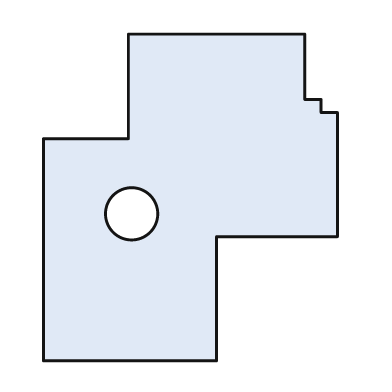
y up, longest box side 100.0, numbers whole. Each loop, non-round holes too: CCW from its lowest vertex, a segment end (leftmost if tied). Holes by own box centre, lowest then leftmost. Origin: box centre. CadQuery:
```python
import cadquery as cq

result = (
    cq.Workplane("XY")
    .moveTo(-45.0, -50.0)
    .lineTo(8.0, -50.0)
    .lineTo(8.0, -12.0)
    .lineTo(45.0, -12.0)
    .lineTo(45.0, 26.0)
    .lineTo(40.0, 26.0)
    .lineTo(40.0, 30.0)
    .lineTo(35.0, 30.0)
    .lineTo(35.0, 50.0)
    .lineTo(-19.0, 50.0)
    .lineTo(-19.0, 18.0)
    .lineTo(-45.0, 18.0)
    .close()
    .moveTo(-18.0, -5.0)
    .circle(8.0)
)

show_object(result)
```